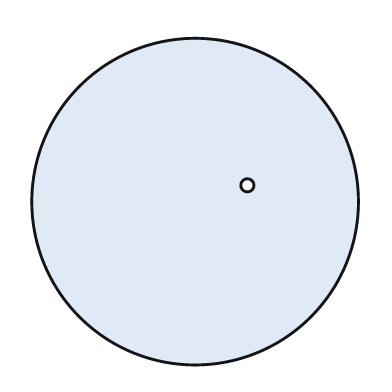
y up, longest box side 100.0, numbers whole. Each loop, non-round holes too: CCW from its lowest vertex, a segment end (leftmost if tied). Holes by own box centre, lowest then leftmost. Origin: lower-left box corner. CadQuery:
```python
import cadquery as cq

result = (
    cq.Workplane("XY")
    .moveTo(50.0, 50.0)
    .circle(50.0)
    .moveTo(66.0, 55.0)
    .circle(2.0)
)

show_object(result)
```